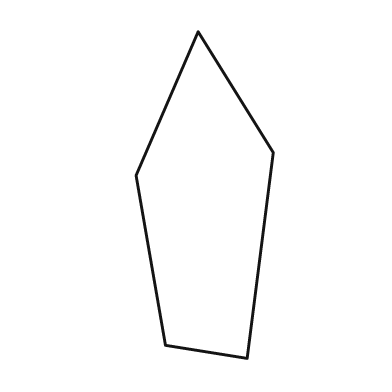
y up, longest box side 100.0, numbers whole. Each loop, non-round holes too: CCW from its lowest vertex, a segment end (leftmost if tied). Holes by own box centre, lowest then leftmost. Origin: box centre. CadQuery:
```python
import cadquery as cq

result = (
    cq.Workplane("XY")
    .moveTo(13.0, -50.0)
    .lineTo(21.0, 13.0)
    .lineTo(-2.0, 50.0)
    .lineTo(-21.0, 6.0)
    .lineTo(-12.0, -46.0)
    .close()
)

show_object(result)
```